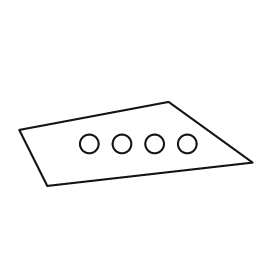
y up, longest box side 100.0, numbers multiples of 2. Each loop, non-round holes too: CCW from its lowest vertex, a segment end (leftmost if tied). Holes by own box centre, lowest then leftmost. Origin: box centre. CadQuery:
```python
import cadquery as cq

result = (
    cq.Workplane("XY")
    .moveTo(-38.0, -18.0)
    .lineTo(50.0, -8.0)
    .lineTo(14.0, 18.0)
    .lineTo(-50.0, 6.0)
    .close()
    .moveTo(-20.0, 0.0)
    .circle(4.0)
    .moveTo(-6.0, 0.0)
    .circle(4.0)
    .moveTo(8.0, 0.0)
    .circle(4.0)
    .moveTo(22.0, 0.0)
    .circle(4.0)
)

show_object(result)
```